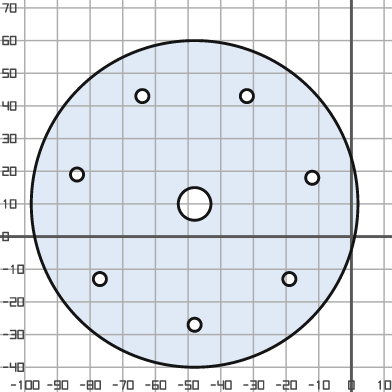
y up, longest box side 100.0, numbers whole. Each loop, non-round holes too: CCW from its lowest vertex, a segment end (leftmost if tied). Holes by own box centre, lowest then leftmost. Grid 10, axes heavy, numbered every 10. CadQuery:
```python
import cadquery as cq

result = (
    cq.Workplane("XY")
    .moveTo(-48.0, 10.0)
    .circle(50.0)
    .moveTo(-48.0, -27.0)
    .circle(2.0)
    .moveTo(-77.0, -13.0)
    .circle(2.0)
    .moveTo(-19.0, -13.0)
    .circle(2.0)
    .moveTo(-48.0, 10.0)
    .circle(5.0)
    .moveTo(-12.0, 18.0)
    .circle(2.0)
    .moveTo(-84.0, 19.0)
    .circle(2.0)
    .moveTo(-64.0, 43.0)
    .circle(2.0)
    .moveTo(-32.0, 43.0)
    .circle(2.0)
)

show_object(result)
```